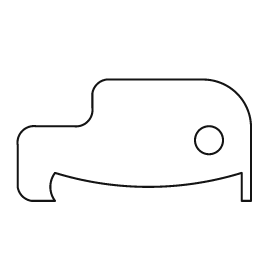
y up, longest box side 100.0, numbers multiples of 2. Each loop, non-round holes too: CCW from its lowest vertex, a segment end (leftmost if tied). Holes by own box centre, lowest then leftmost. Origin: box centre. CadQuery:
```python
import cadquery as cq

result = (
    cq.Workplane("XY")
    .moveTo(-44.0, -26.0)
    .lineTo(-34.0, -26.0)
    .threePointArc((-36.0, -20.0), (-34.0, -14.0))
    .threePointArc((6.0, -20.0), (46.0, -14.0))
    .lineTo(46.0, -26.0)
    .lineTo(50.0, -26.0)
    .lineTo(50.0, 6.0)
    .threePointArc((44.0, 20.0), (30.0, 26.0))
    .lineTo(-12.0, 26.0)
    .threePointArc((-16.0, 24.0), (-18.0, 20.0))
    .lineTo(-18.0, 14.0)
    .threePointArc((-20.0, 8.0), (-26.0, 6.0))
    .lineTo(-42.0, 6.0)
    .threePointArc((-48.0, 4.0), (-50.0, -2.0))
    .lineTo(-50.0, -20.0)
    .threePointArc((-48.0, -24.0), (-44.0, -26.0))
    .close()
    .moveTo(32.0, 0.0)
    .circle(6.0)
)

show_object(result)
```